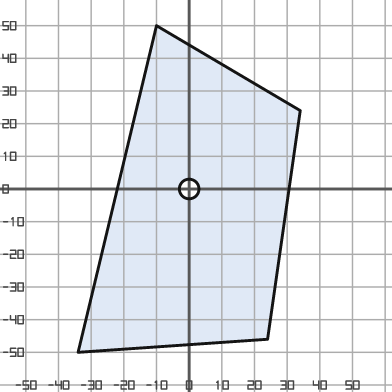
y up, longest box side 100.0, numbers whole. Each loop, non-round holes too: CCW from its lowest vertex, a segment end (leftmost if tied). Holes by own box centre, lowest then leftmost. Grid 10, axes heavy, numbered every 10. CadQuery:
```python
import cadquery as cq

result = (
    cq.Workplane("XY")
    .moveTo(-34.0, -50.0)
    .lineTo(24.0, -46.0)
    .lineTo(34.0, 24.0)
    .lineTo(-10.0, 50.0)
    .close()
    .moveTo(0.0, 0.0)
    .circle(3.0)
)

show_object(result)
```